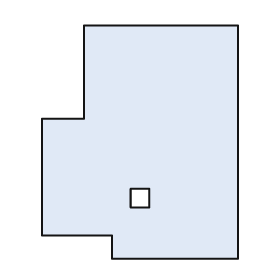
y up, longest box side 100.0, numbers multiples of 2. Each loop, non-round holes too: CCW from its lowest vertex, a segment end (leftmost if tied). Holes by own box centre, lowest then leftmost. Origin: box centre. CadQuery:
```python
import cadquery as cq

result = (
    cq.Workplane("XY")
    .moveTo(-12.0, -50.0)
    .lineTo(42.0, -50.0)
    .lineTo(42.0, 50.0)
    .lineTo(-24.0, 50.0)
    .lineTo(-24.0, 10.0)
    .lineTo(-42.0, 10.0)
    .lineTo(-42.0, -40.0)
    .lineTo(-12.0, -40.0)
    .close()
    .moveTo(-4.0, -28.0)
    .lineTo(4.0, -28.0)
    .lineTo(4.0, -20.0)
    .lineTo(-4.0, -20.0)
    .close()
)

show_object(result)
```